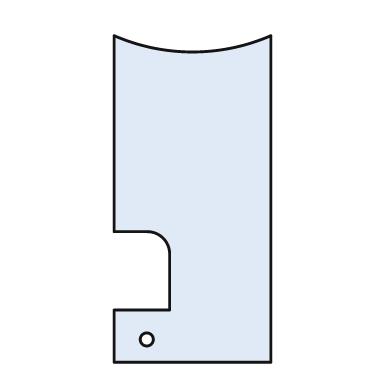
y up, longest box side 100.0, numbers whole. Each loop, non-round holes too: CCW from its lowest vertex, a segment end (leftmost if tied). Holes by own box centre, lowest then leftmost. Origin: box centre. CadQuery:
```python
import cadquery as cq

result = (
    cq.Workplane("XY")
    .moveTo(-24.0, -50.0)
    .lineTo(24.0, -50.0)
    .lineTo(24.0, 50.0)
    .threePointArc((0.0, 45.0), (-24.0, 50.0))
    .lineTo(-24.0, -10.0)
    .lineTo(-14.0, -10.0)
    .threePointArc((-9.0, -12.0), (-7.0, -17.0))
    .lineTo(-7.0, -34.0)
    .lineTo(-24.0, -34.0)
    .close()
    .moveTo(-14.0, -43.0)
    .circle(2.0)
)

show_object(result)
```